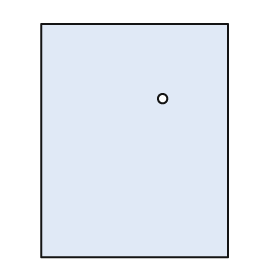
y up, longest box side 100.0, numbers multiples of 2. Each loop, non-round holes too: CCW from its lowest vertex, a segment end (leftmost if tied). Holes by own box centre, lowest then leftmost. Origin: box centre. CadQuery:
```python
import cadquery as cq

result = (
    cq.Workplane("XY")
    .moveTo(-40.0, -50.0)
    .lineTo(40.0, -50.0)
    .lineTo(40.0, 50.0)
    .lineTo(-40.0, 50.0)
    .close()
    .moveTo(12.0, 18.0)
    .circle(2.0)
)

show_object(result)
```